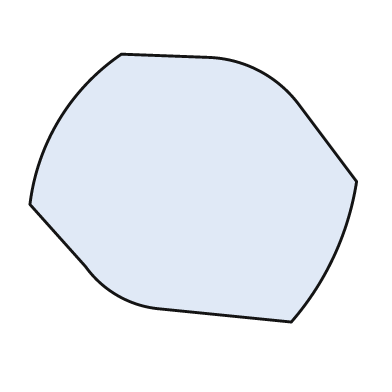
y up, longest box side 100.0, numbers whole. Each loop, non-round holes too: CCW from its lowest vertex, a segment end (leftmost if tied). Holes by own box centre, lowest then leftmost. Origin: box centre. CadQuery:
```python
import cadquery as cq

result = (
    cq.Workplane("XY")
    .moveTo(30.0, -41.0)
    .threePointArc((43.0, -21.0), (50.0, 2.0))
    .lineTo(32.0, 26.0)
    .threePointArc((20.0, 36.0), (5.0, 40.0))
    .lineTo(-22.0, 41.0)
    .threePointArc((-41.0, 21.0), (-50.0, -5.0))
    .lineTo(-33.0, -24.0)
    .threePointArc((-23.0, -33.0), (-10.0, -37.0))
    .close()
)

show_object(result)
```